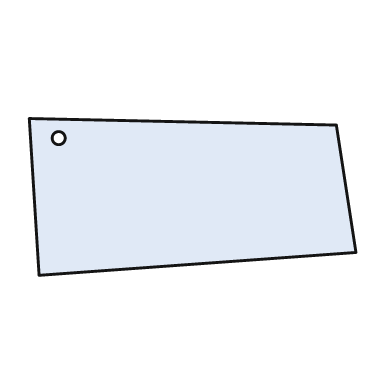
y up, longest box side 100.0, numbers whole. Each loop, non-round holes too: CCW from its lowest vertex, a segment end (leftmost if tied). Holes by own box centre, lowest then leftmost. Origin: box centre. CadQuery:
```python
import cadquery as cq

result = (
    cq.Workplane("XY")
    .moveTo(-47.0, -24.0)
    .lineTo(50.0, -17.0)
    .lineTo(44.0, 22.0)
    .lineTo(-50.0, 24.0)
    .close()
    .moveTo(-41.0, 18.0)
    .circle(2.0)
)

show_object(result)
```